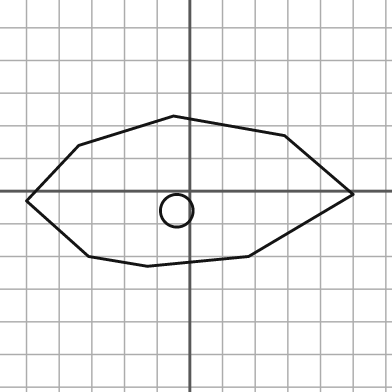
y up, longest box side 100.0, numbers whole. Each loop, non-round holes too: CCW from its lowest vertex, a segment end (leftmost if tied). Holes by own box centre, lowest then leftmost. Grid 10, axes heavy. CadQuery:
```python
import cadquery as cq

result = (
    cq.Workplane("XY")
    .moveTo(-13.0, -23.0)
    .lineTo(18.0, -20.0)
    .lineTo(50.0, -1.0)
    .lineTo(29.0, 17.0)
    .lineTo(-5.0, 23.0)
    .lineTo(-34.0, 14.0)
    .lineTo(-50.0, -3.0)
    .lineTo(-31.0, -20.0)
    .close()
    .moveTo(-4.0, -6.0)
    .circle(5.0)
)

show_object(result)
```